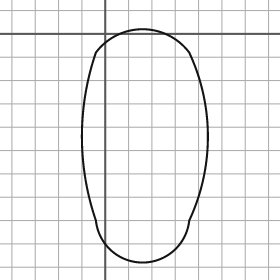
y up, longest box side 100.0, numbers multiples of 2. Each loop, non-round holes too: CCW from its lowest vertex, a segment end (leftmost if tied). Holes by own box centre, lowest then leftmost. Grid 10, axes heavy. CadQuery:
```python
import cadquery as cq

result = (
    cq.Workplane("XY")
    .moveTo(-4.0, -80.0)
    .threePointArc((16.0, -98.0), (36.0, -80.0))
    .threePointArc((44.0, -44.0), (36.0, -8.0))
    .threePointArc((16.0, 2.0), (-4.0, -8.0))
    .threePointArc((-10.0, -44.0), (-4.0, -80.0))
    .close()
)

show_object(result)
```